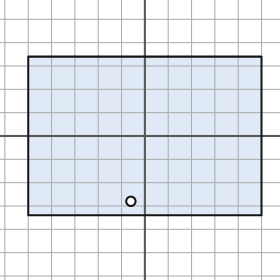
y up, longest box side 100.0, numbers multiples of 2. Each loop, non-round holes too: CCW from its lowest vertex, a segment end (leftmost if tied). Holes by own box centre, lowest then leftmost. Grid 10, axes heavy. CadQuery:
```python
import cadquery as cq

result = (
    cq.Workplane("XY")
    .moveTo(-50.0, -34.0)
    .lineTo(50.0, -34.0)
    .lineTo(50.0, 34.0)
    .lineTo(-50.0, 34.0)
    .close()
    .moveTo(-6.0, -28.0)
    .circle(2.0)
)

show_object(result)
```